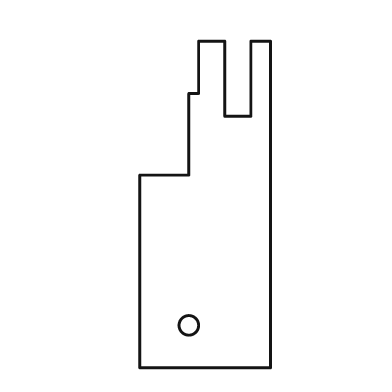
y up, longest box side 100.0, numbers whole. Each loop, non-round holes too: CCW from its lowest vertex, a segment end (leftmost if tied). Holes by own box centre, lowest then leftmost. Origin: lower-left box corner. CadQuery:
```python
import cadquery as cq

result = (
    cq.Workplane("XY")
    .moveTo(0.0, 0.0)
    .lineTo(40.0, 0.0)
    .lineTo(40.0, 100.0)
    .lineTo(34.0, 100.0)
    .lineTo(34.0, 77.0)
    .lineTo(26.0, 77.0)
    .lineTo(26.0, 100.0)
    .lineTo(18.0, 100.0)
    .lineTo(18.0, 84.0)
    .lineTo(15.0, 84.0)
    .lineTo(15.0, 59.0)
    .lineTo(0.0, 59.0)
    .close()
    .moveTo(15.0, 13.0)
    .circle(3.0)
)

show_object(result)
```